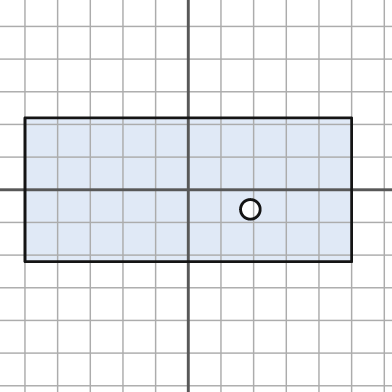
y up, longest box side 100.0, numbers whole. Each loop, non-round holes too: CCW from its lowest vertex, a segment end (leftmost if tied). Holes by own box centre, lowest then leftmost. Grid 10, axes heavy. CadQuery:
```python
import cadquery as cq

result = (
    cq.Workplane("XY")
    .moveTo(-50.0, -22.0)
    .lineTo(50.0, -22.0)
    .lineTo(50.0, 22.0)
    .lineTo(-50.0, 22.0)
    .close()
    .moveTo(19.0, -6.0)
    .circle(3.0)
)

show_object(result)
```